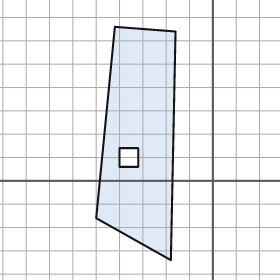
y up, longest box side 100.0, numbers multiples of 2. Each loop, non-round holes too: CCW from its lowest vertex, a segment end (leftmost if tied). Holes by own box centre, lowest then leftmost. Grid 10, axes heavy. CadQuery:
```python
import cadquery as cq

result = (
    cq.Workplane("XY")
    .moveTo(-18.0, -34.0)
    .lineTo(-16.0, 64.0)
    .lineTo(-42.0, 66.0)
    .lineTo(-50.0, -16.0)
    .close()
    .moveTo(-40.0, 6.0)
    .lineTo(-32.0, 6.0)
    .lineTo(-32.0, 14.0)
    .lineTo(-40.0, 14.0)
    .close()
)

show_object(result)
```